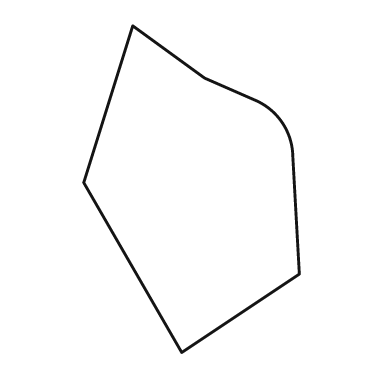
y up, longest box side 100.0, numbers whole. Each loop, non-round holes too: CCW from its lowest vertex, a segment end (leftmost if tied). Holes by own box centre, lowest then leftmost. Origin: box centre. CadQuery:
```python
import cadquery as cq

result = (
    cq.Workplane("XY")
    .moveTo(-3.0, -50.0)
    .lineTo(33.0, -26.0)
    .lineTo(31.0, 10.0)
    .threePointArc((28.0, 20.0), (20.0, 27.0))
    .lineTo(4.0, 34.0)
    .lineTo(-18.0, 50.0)
    .lineTo(-33.0, 2.0)
    .close()
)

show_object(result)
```